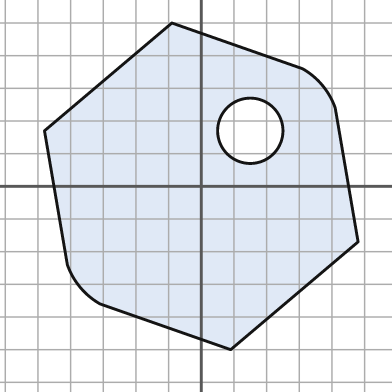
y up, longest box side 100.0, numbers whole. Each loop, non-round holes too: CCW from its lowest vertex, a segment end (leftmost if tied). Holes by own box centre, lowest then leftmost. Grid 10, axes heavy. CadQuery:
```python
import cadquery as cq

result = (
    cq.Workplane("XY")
    .moveTo(9.0, -50.0)
    .lineTo(48.0, -17.0)
    .lineTo(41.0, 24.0)
    .threePointArc((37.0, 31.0), (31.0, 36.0))
    .lineTo(-9.0, 50.0)
    .lineTo(-48.0, 17.0)
    .lineTo(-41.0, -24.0)
    .threePointArc((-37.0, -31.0), (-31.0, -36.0))
    .close()
    .moveTo(15.0, 17.0)
    .circle(10.0)
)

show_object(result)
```